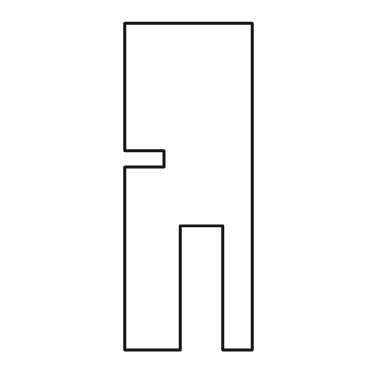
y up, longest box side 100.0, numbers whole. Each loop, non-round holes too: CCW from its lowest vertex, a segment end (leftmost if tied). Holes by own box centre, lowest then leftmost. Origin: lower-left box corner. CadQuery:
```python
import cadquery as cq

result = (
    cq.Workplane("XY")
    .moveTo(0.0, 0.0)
    .lineTo(17.0, 0.0)
    .lineTo(17.0, 38.0)
    .lineTo(30.0, 38.0)
    .lineTo(30.0, 0.0)
    .lineTo(39.0, 0.0)
    .lineTo(39.0, 100.0)
    .lineTo(0.0, 100.0)
    .lineTo(0.0, 61.0)
    .lineTo(12.0, 61.0)
    .lineTo(12.0, 56.0)
    .lineTo(0.0, 56.0)
    .close()
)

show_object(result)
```